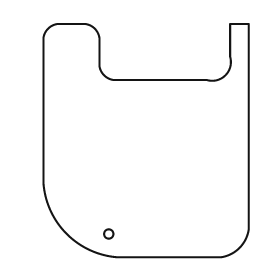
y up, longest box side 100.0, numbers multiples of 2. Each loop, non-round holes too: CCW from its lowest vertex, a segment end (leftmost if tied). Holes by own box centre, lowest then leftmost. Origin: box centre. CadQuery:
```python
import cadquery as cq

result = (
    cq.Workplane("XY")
    .moveTo(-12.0, -50.0)
    .lineTo(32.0, -50.0)
    .threePointArc((40.0, -46.0), (44.0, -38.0))
    .lineTo(44.0, 50.0)
    .lineTo(36.0, 50.0)
    .lineTo(36.0, 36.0)
    .threePointArc((34.0, 28.0), (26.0, 26.0))
    .lineTo(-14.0, 26.0)
    .threePointArc((-18.0, 28.0), (-20.0, 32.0))
    .lineTo(-20.0, 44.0)
    .threePointArc((-22.0, 48.0), (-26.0, 50.0))
    .lineTo(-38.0, 50.0)
    .threePointArc((-42.0, 48.0), (-44.0, 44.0))
    .lineTo(-44.0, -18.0)
    .threePointArc((-34.0, -40.0), (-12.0, -50.0))
    .close()
    .moveTo(-16.0, -40.0)
    .circle(2.0)
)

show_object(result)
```